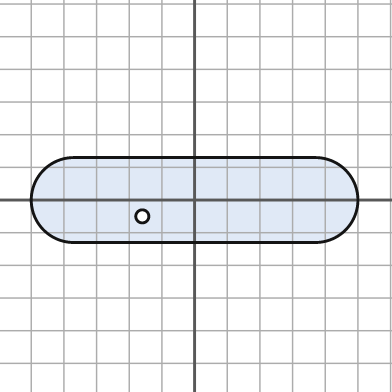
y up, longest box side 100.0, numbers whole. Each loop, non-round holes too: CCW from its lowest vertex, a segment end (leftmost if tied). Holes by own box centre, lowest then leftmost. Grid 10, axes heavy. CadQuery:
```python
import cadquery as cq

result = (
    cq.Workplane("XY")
    .moveTo(-37.0, -13.0)
    .lineTo(37.0, -13.0)
    .threePointArc((50.0, 0.0), (37.0, 13.0))
    .lineTo(-37.0, 13.0)
    .threePointArc((-50.0, 0.0), (-37.0, -13.0))
    .close()
    .moveTo(-16.0, -5.0)
    .circle(2.0)
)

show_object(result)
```